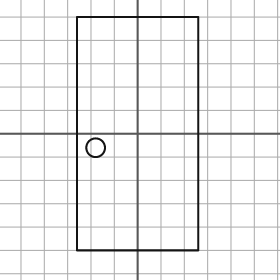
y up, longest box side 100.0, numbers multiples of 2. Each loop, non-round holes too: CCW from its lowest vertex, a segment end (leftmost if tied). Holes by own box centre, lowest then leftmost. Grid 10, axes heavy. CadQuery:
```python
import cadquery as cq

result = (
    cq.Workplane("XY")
    .moveTo(-26.0, -50.0)
    .lineTo(26.0, -50.0)
    .lineTo(26.0, 50.0)
    .lineTo(-26.0, 50.0)
    .close()
    .moveTo(-18.0, -6.0)
    .circle(4.0)
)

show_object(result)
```